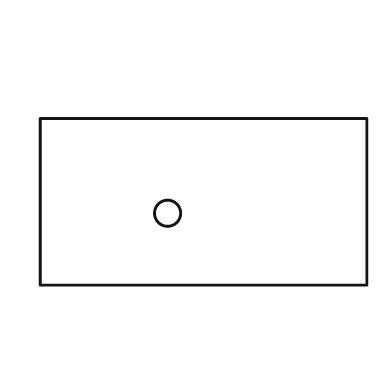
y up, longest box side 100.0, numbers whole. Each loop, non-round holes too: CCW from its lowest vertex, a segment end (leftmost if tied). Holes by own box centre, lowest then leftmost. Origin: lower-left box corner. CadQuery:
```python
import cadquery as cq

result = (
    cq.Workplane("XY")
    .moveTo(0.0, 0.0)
    .lineTo(100.0, 0.0)
    .lineTo(100.0, 51.0)
    .lineTo(0.0, 51.0)
    .close()
    .moveTo(39.0, 22.0)
    .circle(4.0)
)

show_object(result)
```